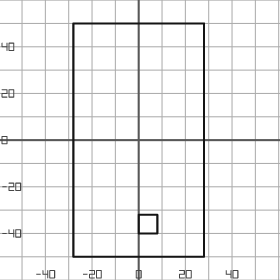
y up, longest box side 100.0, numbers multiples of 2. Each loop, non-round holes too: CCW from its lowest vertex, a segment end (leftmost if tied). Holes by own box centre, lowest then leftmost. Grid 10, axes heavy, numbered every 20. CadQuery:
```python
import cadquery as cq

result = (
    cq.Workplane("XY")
    .moveTo(-28.0, -50.0)
    .lineTo(28.0, -50.0)
    .lineTo(28.0, 50.0)
    .lineTo(-28.0, 50.0)
    .close()
    .moveTo(0.0, -40.0)
    .lineTo(8.0, -40.0)
    .lineTo(8.0, -32.0)
    .lineTo(0.0, -32.0)
    .close()
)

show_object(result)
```